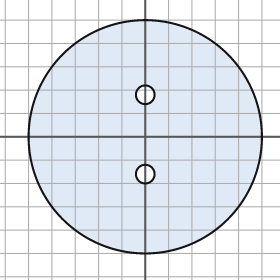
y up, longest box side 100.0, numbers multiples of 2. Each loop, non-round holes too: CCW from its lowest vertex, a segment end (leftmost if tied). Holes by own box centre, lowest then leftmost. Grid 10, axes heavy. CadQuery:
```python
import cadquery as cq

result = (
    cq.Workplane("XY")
    .moveTo(0.0, 0.0)
    .circle(50.0)
    .moveTo(0.0, -16.0)
    .circle(4.0)
    .moveTo(0.0, 18.0)
    .circle(4.0)
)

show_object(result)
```